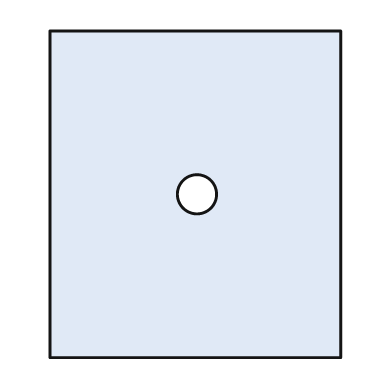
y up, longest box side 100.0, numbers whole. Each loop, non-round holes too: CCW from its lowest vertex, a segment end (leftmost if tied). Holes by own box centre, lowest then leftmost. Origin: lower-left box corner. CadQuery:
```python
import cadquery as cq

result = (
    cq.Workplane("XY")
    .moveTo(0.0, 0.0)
    .lineTo(89.0, 0.0)
    .lineTo(89.0, 100.0)
    .lineTo(0.0, 100.0)
    .close()
    .moveTo(45.0, 50.0)
    .circle(6.0)
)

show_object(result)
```